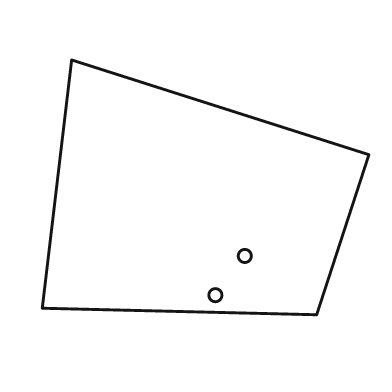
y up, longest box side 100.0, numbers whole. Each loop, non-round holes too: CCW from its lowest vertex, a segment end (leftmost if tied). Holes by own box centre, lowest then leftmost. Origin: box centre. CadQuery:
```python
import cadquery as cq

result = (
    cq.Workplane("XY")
    .moveTo(34.0, -39.0)
    .lineTo(50.0, 10.0)
    .lineTo(-41.0, 39.0)
    .lineTo(-50.0, -37.0)
    .close()
    .moveTo(3.0, -33.0)
    .circle(2.0)
    .moveTo(12.0, -21.0)
    .circle(2.0)
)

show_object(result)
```